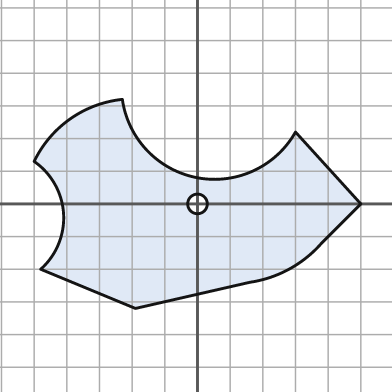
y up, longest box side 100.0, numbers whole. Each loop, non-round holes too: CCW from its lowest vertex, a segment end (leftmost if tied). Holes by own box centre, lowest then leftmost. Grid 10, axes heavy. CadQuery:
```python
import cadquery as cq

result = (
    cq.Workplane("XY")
    .moveTo(-19.0, -32.0)
    .lineTo(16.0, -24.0)
    .threePointArc((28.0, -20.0), (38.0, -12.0))
    .lineTo(50.0, 0.0)
    .lineTo(30.0, 22.0)
    .threePointArc((0.0, 8.0), (-23.0, 32.0))
    .threePointArc((-39.0, 26.0), (-50.0, 13.0))
    .threePointArc((-41.0, -3.0), (-48.0, -20.0))
    .close()
    .moveTo(0.0, 0.0)
    .circle(3.0)
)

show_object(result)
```